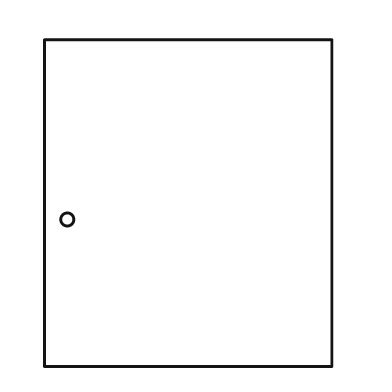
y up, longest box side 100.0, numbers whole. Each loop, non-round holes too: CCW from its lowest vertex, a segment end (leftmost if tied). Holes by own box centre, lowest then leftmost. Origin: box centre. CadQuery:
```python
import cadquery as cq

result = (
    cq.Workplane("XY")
    .moveTo(-44.0, -50.0)
    .lineTo(44.0, -50.0)
    .lineTo(44.0, 50.0)
    .lineTo(-44.0, 50.0)
    .close()
    .moveTo(-37.0, -5.0)
    .circle(2.0)
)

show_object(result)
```